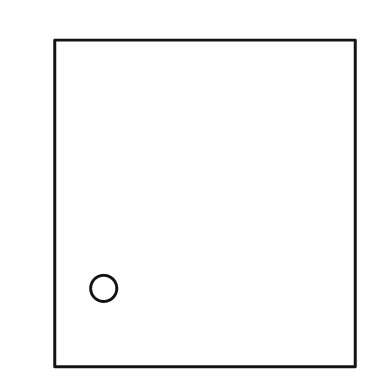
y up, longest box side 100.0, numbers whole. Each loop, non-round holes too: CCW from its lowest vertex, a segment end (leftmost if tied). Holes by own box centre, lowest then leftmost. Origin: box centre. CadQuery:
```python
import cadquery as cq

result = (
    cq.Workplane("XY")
    .moveTo(-46.0, -50.0)
    .lineTo(46.0, -50.0)
    .lineTo(46.0, 50.0)
    .lineTo(-46.0, 50.0)
    .close()
    .moveTo(-31.0, -26.0)
    .circle(4.0)
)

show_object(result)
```